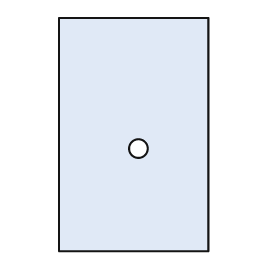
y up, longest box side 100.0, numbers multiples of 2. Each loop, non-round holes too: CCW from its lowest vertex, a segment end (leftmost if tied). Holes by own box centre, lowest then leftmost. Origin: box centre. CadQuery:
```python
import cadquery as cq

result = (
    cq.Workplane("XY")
    .moveTo(-32.0, -50.0)
    .lineTo(32.0, -50.0)
    .lineTo(32.0, 50.0)
    .lineTo(-32.0, 50.0)
    .close()
    .moveTo(2.0, -6.0)
    .circle(4.0)
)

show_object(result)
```